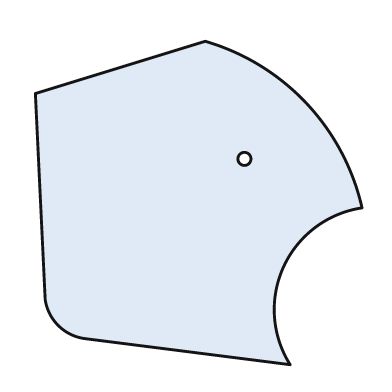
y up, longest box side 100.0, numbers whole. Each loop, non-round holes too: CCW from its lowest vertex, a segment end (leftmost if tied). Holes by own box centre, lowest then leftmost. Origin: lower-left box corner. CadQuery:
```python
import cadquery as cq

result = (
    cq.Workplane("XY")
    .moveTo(78.0, 0.0)
    .threePointArc((76.0, 30.0), (100.0, 48.0))
    .threePointArc((83.0, 80.0), (52.0, 99.0))
    .lineTo(0.0, 83.0)
    .lineTo(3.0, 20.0)
    .threePointArc((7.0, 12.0), (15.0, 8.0))
    .close()
    .moveTo(64.0, 63.0)
    .circle(2.0)
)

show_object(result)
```